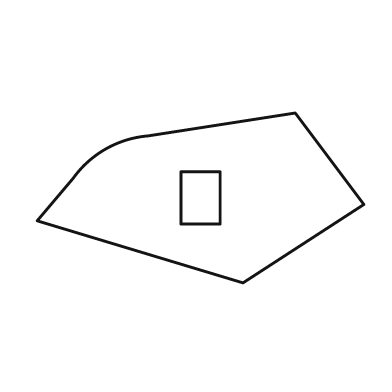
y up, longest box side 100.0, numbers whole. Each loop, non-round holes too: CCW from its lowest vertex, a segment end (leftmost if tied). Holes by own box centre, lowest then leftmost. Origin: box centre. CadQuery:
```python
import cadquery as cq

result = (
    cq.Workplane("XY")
    .moveTo(13.0, -26.0)
    .lineTo(50.0, -2.0)
    .lineTo(29.0, 26.0)
    .lineTo(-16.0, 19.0)
    .threePointArc((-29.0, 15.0), (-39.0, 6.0))
    .lineTo(-50.0, -7.0)
    .close()
    .moveTo(-6.0, -8.0)
    .lineTo(6.0, -8.0)
    .lineTo(6.0, 8.0)
    .lineTo(-6.0, 8.0)
    .close()
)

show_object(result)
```